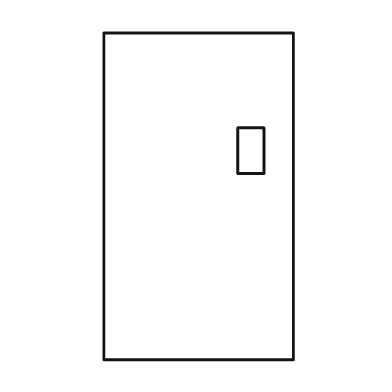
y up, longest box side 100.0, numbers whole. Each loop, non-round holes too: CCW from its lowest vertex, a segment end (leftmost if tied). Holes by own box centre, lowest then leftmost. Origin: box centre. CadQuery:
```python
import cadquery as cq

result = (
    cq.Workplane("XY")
    .moveTo(-29.0, -50.0)
    .lineTo(29.0, -50.0)
    .lineTo(29.0, 50.0)
    .lineTo(-29.0, 50.0)
    .close()
    .moveTo(12.0, 7.0)
    .lineTo(20.0, 7.0)
    .lineTo(20.0, 21.0)
    .lineTo(12.0, 21.0)
    .close()
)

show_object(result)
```